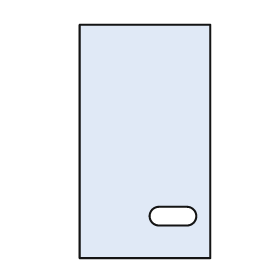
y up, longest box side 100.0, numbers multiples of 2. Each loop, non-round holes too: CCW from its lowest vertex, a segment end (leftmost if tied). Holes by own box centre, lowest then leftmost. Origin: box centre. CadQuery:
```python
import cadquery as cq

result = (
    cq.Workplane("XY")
    .moveTo(-28.0, -50.0)
    .lineTo(28.0, -50.0)
    .lineTo(28.0, 50.0)
    .lineTo(-28.0, 50.0)
    .close()
    .moveTo(6.0, -36.0)
    .lineTo(18.0, -36.0)
    .threePointArc((22.0, -32.0), (18.0, -28.0))
    .lineTo(6.0, -28.0)
    .threePointArc((2.0, -32.0), (6.0, -36.0))
    .close()
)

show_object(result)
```